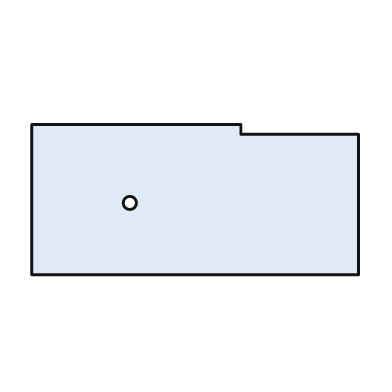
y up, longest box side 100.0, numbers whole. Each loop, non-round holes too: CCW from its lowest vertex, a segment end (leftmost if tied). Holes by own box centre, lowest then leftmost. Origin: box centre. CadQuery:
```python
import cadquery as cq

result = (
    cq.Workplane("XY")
    .moveTo(-50.0, -23.0)
    .lineTo(50.0, -23.0)
    .lineTo(50.0, 20.0)
    .lineTo(14.0, 20.0)
    .lineTo(14.0, 23.0)
    .lineTo(-50.0, 23.0)
    .close()
    .moveTo(-20.0, -1.0)
    .circle(2.0)
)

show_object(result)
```